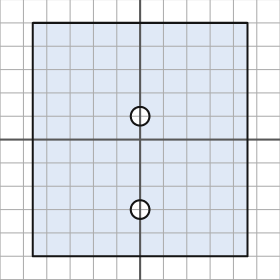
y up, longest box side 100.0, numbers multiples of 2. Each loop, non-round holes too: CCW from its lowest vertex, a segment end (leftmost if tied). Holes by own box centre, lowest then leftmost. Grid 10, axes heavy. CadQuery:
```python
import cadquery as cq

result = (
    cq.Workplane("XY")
    .moveTo(-46.0, -50.0)
    .lineTo(46.0, -50.0)
    .lineTo(46.0, 50.0)
    .lineTo(-46.0, 50.0)
    .close()
    .moveTo(0.0, -30.0)
    .circle(4.0)
    .moveTo(0.0, 10.0)
    .circle(4.0)
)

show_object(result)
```